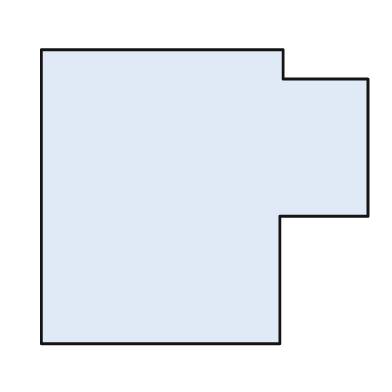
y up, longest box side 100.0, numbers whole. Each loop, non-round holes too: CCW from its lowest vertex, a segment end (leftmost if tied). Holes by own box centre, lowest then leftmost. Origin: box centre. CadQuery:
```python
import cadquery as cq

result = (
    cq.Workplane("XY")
    .moveTo(-50.0, -45.0)
    .lineTo(23.0, -45.0)
    .lineTo(23.0, -6.0)
    .lineTo(50.0, -6.0)
    .lineTo(50.0, 36.0)
    .lineTo(24.0, 36.0)
    .lineTo(24.0, 45.0)
    .lineTo(-50.0, 45.0)
    .close()
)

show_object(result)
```